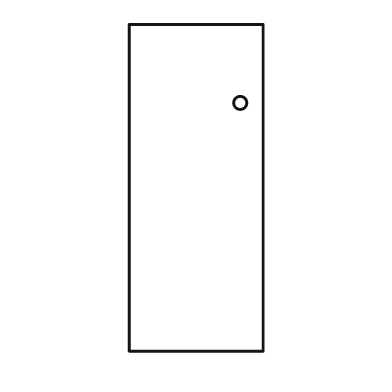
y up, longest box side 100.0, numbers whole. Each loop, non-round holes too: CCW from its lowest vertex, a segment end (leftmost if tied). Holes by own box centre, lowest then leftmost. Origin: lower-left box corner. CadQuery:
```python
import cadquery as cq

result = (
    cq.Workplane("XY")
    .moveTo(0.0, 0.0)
    .lineTo(41.0, 0.0)
    .lineTo(41.0, 100.0)
    .lineTo(0.0, 100.0)
    .close()
    .moveTo(34.0, 76.0)
    .circle(2.0)
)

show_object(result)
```